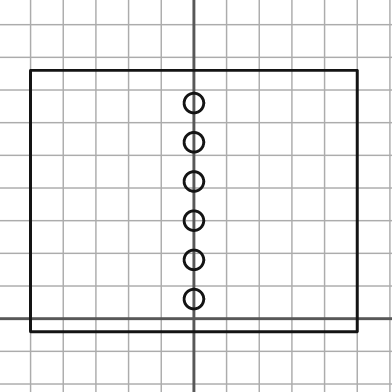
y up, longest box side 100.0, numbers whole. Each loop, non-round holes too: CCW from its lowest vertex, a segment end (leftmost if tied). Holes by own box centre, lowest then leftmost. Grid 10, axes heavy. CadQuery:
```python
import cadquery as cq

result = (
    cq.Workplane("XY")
    .moveTo(-50.0, -4.0)
    .lineTo(50.0, -4.0)
    .lineTo(50.0, 76.0)
    .lineTo(-50.0, 76.0)
    .close()
    .moveTo(0.0, 6.0)
    .circle(3.0)
    .moveTo(0.0, 18.0)
    .circle(3.0)
    .moveTo(0.0, 30.0)
    .circle(3.0)
    .moveTo(0.0, 42.0)
    .circle(3.0)
    .moveTo(0.0, 54.0)
    .circle(3.0)
    .moveTo(0.0, 66.0)
    .circle(3.0)
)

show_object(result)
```